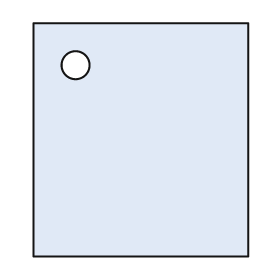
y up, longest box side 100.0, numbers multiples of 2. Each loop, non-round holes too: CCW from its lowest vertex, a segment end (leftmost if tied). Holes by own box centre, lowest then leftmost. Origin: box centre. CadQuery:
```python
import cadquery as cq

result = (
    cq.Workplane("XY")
    .moveTo(-46.0, -50.0)
    .lineTo(46.0, -50.0)
    .lineTo(46.0, 50.0)
    .lineTo(-46.0, 50.0)
    .close()
    .moveTo(-28.0, 32.0)
    .circle(6.0)
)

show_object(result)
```